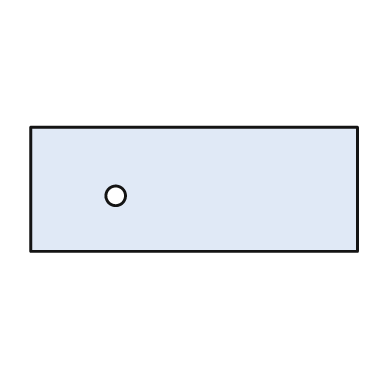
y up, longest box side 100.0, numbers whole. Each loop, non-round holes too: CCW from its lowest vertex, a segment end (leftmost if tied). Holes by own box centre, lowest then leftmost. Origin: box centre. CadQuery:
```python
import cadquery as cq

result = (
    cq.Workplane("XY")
    .moveTo(-50.0, -19.0)
    .lineTo(50.0, -19.0)
    .lineTo(50.0, 19.0)
    .lineTo(-50.0, 19.0)
    .close()
    .moveTo(-24.0, -2.0)
    .circle(3.0)
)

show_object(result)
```